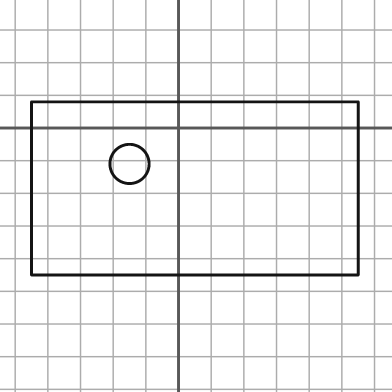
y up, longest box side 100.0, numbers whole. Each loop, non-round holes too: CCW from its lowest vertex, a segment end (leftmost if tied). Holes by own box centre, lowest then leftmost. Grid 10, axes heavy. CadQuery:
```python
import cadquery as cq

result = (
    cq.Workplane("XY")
    .moveTo(-45.0, -45.0)
    .lineTo(55.0, -45.0)
    .lineTo(55.0, 8.0)
    .lineTo(-45.0, 8.0)
    .close()
    .moveTo(-15.0, -11.0)
    .circle(6.0)
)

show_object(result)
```